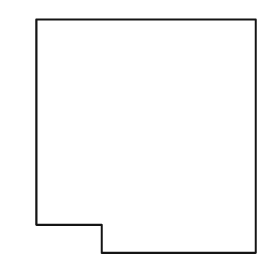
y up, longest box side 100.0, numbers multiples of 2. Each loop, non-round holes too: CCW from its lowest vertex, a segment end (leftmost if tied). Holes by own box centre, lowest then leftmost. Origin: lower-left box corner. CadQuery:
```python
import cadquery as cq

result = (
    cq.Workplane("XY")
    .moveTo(28.0, 0.0)
    .lineTo(94.0, 0.0)
    .lineTo(94.0, 100.0)
    .lineTo(0.0, 100.0)
    .lineTo(0.0, 12.0)
    .lineTo(28.0, 12.0)
    .close()
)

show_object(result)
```